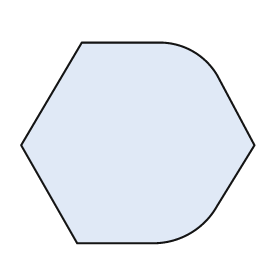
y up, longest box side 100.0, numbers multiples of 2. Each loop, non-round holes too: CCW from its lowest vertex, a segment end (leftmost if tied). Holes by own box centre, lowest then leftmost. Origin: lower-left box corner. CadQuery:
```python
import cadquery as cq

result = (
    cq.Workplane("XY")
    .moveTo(24.0, 0.0)
    .lineTo(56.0, 0.0)
    .threePointArc((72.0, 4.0), (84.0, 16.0))
    .lineTo(100.0, 42.0)
    .lineTo(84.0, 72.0)
    .threePointArc((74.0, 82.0), (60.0, 86.0))
    .lineTo(26.0, 86.0)
    .lineTo(0.0, 42.0)
    .close()
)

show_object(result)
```